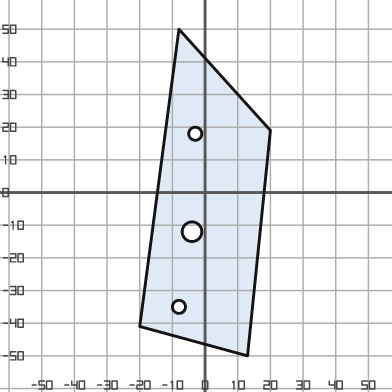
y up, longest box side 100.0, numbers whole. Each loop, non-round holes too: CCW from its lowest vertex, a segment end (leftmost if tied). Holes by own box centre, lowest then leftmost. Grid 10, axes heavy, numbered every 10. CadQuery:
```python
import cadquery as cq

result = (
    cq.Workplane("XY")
    .moveTo(13.0, -50.0)
    .lineTo(20.0, 19.0)
    .lineTo(-8.0, 50.0)
    .lineTo(-20.0, -41.0)
    .close()
    .moveTo(-8.0, -35.0)
    .circle(2.0)
    .moveTo(-4.0, -12.0)
    .circle(3.0)
    .moveTo(-3.0, 18.0)
    .circle(2.0)
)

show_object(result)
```